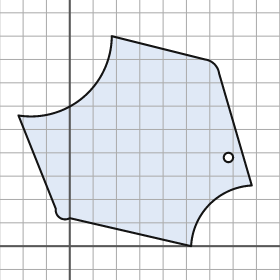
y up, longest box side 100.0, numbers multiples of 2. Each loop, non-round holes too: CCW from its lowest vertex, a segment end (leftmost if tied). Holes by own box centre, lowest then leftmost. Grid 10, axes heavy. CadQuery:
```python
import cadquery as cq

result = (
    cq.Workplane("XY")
    .moveTo(52.0, 0.0)
    .threePointArc((60.0, 18.0), (78.0, 26.0))
    .lineTo(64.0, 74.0)
    .threePointArc((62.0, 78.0), (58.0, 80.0))
    .lineTo(18.0, 90.0)
    .threePointArc((6.0, 64.0), (-22.0, 56.0))
    .lineTo(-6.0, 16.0)
    .threePointArc((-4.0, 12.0), (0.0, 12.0))
    .close()
    .moveTo(68.0, 38.0)
    .circle(2.0)
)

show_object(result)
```